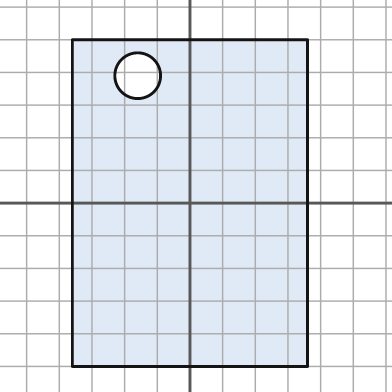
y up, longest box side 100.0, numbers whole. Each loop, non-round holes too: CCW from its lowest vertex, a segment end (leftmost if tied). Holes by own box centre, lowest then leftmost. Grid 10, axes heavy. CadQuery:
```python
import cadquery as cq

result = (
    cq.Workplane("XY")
    .moveTo(-36.0, -50.0)
    .lineTo(36.0, -50.0)
    .lineTo(36.0, 50.0)
    .lineTo(-36.0, 50.0)
    .close()
    .moveTo(-16.0, 39.0)
    .circle(7.0)
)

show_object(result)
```